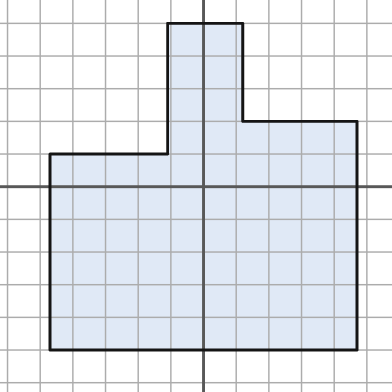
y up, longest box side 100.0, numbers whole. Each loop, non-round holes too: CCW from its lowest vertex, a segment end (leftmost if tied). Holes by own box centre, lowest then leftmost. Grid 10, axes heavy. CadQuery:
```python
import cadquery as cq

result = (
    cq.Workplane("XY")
    .moveTo(-47.0, -50.0)
    .lineTo(47.0, -50.0)
    .lineTo(47.0, 20.0)
    .lineTo(12.0, 20.0)
    .lineTo(12.0, 50.0)
    .lineTo(-11.0, 50.0)
    .lineTo(-11.0, 10.0)
    .lineTo(-47.0, 10.0)
    .close()
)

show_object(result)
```